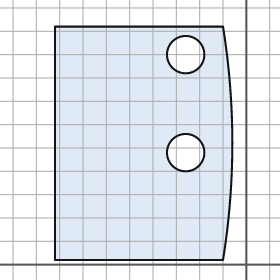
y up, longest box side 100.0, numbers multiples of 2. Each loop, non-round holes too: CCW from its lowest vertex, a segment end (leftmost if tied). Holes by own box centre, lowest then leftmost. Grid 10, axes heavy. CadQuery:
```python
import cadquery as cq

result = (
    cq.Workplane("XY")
    .moveTo(-82.0, 2.0)
    .lineTo(-10.0, 2.0)
    .threePointArc((-6.0, 52.0), (-10.0, 102.0))
    .lineTo(-82.0, 102.0)
    .close()
    .moveTo(-26.0, 48.0)
    .circle(8.0)
    .moveTo(-26.0, 90.0)
    .circle(8.0)
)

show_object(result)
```